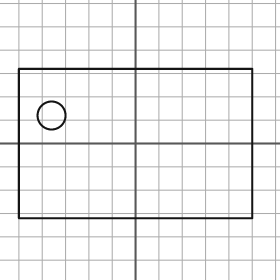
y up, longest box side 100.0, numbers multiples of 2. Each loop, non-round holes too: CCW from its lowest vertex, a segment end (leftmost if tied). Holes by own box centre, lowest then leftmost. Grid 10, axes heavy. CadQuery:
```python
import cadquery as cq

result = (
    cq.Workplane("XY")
    .moveTo(-50.0, -32.0)
    .lineTo(50.0, -32.0)
    .lineTo(50.0, 32.0)
    .lineTo(-50.0, 32.0)
    .close()
    .moveTo(-36.0, 12.0)
    .circle(6.0)
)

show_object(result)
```